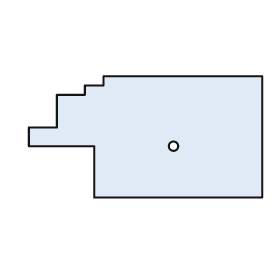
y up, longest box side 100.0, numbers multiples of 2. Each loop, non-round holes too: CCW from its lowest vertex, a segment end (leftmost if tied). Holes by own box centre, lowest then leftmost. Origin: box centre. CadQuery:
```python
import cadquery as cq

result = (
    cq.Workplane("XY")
    .moveTo(-22.0, -26.0)
    .lineTo(50.0, -26.0)
    .lineTo(50.0, 26.0)
    .lineTo(-18.0, 26.0)
    .lineTo(-18.0, 22.0)
    .lineTo(-26.0, 22.0)
    .lineTo(-26.0, 18.0)
    .lineTo(-38.0, 18.0)
    .lineTo(-38.0, 4.0)
    .lineTo(-50.0, 4.0)
    .lineTo(-50.0, -4.0)
    .lineTo(-22.0, -4.0)
    .close()
    .moveTo(12.0, -4.0)
    .circle(2.0)
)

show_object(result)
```